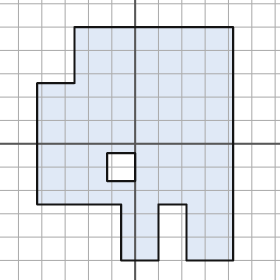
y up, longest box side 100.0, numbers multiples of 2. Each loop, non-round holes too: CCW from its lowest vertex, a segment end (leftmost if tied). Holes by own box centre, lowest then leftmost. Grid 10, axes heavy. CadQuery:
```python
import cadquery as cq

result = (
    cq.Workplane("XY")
    .moveTo(-6.0, -50.0)
    .lineTo(10.0, -50.0)
    .lineTo(10.0, -26.0)
    .lineTo(22.0, -26.0)
    .lineTo(22.0, -50.0)
    .lineTo(42.0, -50.0)
    .lineTo(42.0, 50.0)
    .lineTo(-26.0, 50.0)
    .lineTo(-26.0, 26.0)
    .lineTo(-42.0, 26.0)
    .lineTo(-42.0, -26.0)
    .lineTo(-6.0, -26.0)
    .close()
    .moveTo(-12.0, -16.0)
    .lineTo(0.0, -16.0)
    .lineTo(0.0, -4.0)
    .lineTo(-12.0, -4.0)
    .close()
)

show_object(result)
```